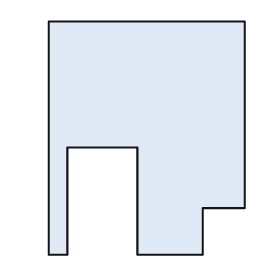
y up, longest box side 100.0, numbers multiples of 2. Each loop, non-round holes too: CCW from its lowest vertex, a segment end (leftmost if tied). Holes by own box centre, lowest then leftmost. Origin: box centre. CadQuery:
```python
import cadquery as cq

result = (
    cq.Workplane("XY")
    .moveTo(-42.0, -50.0)
    .lineTo(-34.0, -50.0)
    .lineTo(-34.0, -4.0)
    .lineTo(-4.0, -4.0)
    .lineTo(-4.0, -50.0)
    .lineTo(24.0, -50.0)
    .lineTo(24.0, -30.0)
    .lineTo(42.0, -30.0)
    .lineTo(42.0, 50.0)
    .lineTo(-42.0, 50.0)
    .close()
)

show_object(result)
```